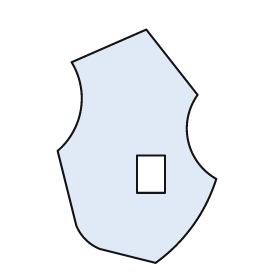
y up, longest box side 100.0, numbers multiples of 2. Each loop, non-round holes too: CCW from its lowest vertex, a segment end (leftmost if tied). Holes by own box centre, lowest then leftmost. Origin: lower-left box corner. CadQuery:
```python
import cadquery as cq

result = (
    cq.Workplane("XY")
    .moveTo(42.0, 0.0)
    .threePointArc((58.0, 16.0), (68.0, 36.0))
    .threePointArc((56.0, 52.0), (60.0, 72.0))
    .lineTo(38.0, 100.0)
    .lineTo(6.0, 86.0)
    .threePointArc((10.0, 66.0), (0.0, 48.0))
    .lineTo(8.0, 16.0)
    .threePointArc((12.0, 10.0), (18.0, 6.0))
    .close()
    .moveTo(34.0, 30.0)
    .lineTo(46.0, 30.0)
    .lineTo(46.0, 46.0)
    .lineTo(34.0, 46.0)
    .close()
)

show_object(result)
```